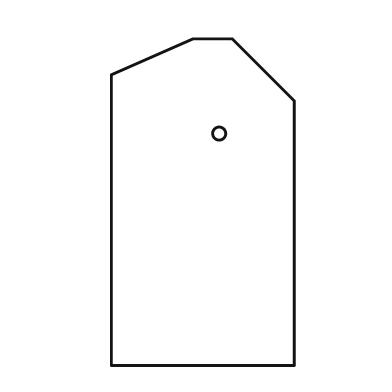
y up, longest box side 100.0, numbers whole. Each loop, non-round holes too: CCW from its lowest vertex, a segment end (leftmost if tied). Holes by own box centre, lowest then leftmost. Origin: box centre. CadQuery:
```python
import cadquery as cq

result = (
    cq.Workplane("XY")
    .moveTo(-28.0, -50.0)
    .lineTo(28.0, -50.0)
    .lineTo(28.0, 31.0)
    .lineTo(9.0, 50.0)
    .lineTo(-3.0, 50.0)
    .lineTo(-28.0, 39.0)
    .close()
    .moveTo(5.0, 21.0)
    .circle(2.0)
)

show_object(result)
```